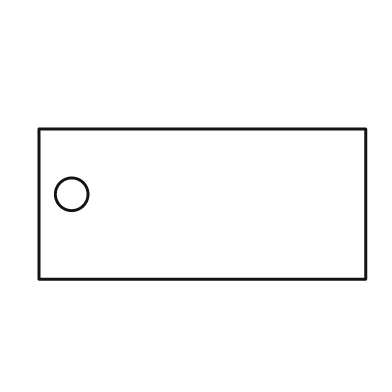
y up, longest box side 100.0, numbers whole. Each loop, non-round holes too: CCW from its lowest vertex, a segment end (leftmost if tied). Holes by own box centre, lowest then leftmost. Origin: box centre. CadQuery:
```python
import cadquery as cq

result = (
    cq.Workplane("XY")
    .moveTo(-50.0, -23.0)
    .lineTo(50.0, -23.0)
    .lineTo(50.0, 23.0)
    .lineTo(-50.0, 23.0)
    .close()
    .moveTo(-40.0, 3.0)
    .circle(5.0)
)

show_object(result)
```